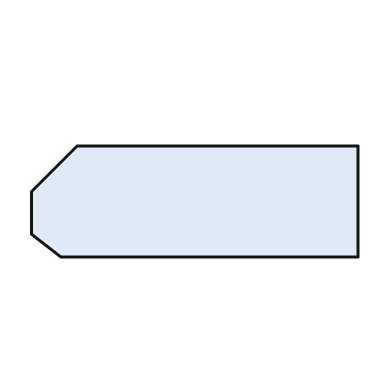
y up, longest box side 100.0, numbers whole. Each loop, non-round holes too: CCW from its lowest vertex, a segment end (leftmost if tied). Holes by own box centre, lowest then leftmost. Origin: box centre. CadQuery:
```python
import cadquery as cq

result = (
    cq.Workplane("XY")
    .moveTo(-41.0, -17.0)
    .lineTo(50.0, -17.0)
    .lineTo(50.0, 17.0)
    .lineTo(-36.0, 17.0)
    .lineTo(-50.0, 3.0)
    .lineTo(-50.0, -10.0)
    .close()
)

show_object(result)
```